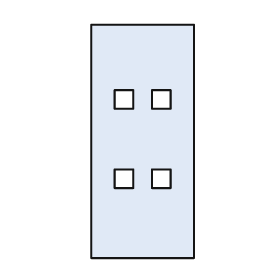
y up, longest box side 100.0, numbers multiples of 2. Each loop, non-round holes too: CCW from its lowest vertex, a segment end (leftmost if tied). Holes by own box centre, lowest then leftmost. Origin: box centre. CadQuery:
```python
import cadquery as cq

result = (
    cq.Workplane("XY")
    .moveTo(-22.0, -50.0)
    .lineTo(22.0, -50.0)
    .lineTo(22.0, 50.0)
    .lineTo(-22.0, 50.0)
    .close()
    .moveTo(-12.0, -20.0)
    .lineTo(-4.0, -20.0)
    .lineTo(-4.0, -12.0)
    .lineTo(-12.0, -12.0)
    .close()
    .moveTo(4.0, -20.0)
    .lineTo(12.0, -20.0)
    .lineTo(12.0, -12.0)
    .lineTo(4.0, -12.0)
    .close()
    .moveTo(-12.0, 14.0)
    .lineTo(-4.0, 14.0)
    .lineTo(-4.0, 22.0)
    .lineTo(-12.0, 22.0)
    .close()
    .moveTo(4.0, 14.0)
    .lineTo(12.0, 14.0)
    .lineTo(12.0, 22.0)
    .lineTo(4.0, 22.0)
    .close()
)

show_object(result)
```